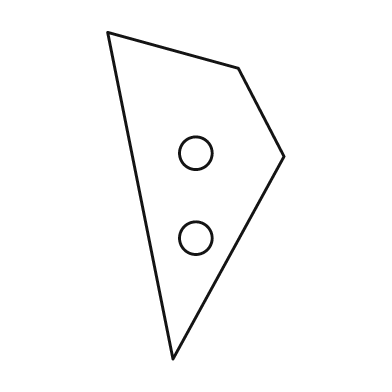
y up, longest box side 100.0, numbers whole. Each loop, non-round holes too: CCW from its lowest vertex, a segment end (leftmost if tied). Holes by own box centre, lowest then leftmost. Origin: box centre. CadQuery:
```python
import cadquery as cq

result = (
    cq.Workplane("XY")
    .moveTo(-7.0, -50.0)
    .lineTo(27.0, 12.0)
    .lineTo(13.0, 39.0)
    .lineTo(-27.0, 50.0)
    .close()
    .moveTo(0.0, -13.0)
    .circle(5.0)
    .moveTo(0.0, 13.0)
    .circle(5.0)
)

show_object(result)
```